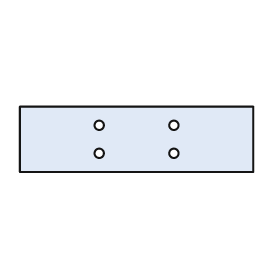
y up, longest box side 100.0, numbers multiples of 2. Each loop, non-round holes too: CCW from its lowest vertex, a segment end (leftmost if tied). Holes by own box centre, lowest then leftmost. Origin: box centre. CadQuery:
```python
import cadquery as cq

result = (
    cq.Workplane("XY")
    .moveTo(-50.0, -14.0)
    .lineTo(50.0, -14.0)
    .lineTo(50.0, 14.0)
    .lineTo(-50.0, 14.0)
    .close()
    .moveTo(-16.0, -6.0)
    .circle(2.0)
    .moveTo(16.0, -6.0)
    .circle(2.0)
    .moveTo(-16.0, 6.0)
    .circle(2.0)
    .moveTo(16.0, 6.0)
    .circle(2.0)
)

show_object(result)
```